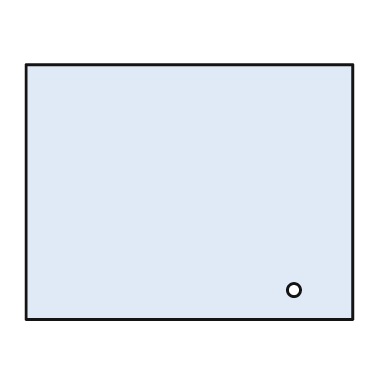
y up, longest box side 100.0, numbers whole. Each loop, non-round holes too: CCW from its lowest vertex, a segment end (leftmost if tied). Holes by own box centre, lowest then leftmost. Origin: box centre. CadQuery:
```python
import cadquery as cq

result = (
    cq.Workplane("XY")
    .moveTo(-50.0, -39.0)
    .lineTo(50.0, -39.0)
    .lineTo(50.0, 39.0)
    .lineTo(-50.0, 39.0)
    .close()
    .moveTo(32.0, -30.0)
    .circle(2.0)
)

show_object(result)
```